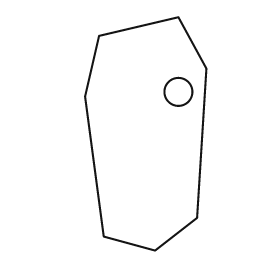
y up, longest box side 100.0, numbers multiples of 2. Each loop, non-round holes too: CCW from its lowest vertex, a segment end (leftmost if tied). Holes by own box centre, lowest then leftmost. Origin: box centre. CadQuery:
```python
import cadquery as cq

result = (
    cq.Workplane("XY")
    .moveTo(4.0, -50.0)
    .lineTo(22.0, -36.0)
    .lineTo(26.0, 28.0)
    .lineTo(14.0, 50.0)
    .lineTo(-20.0, 42.0)
    .lineTo(-26.0, 16.0)
    .lineTo(-18.0, -44.0)
    .close()
    .moveTo(14.0, 18.0)
    .circle(6.0)
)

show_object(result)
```